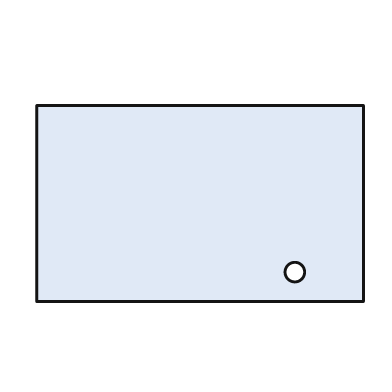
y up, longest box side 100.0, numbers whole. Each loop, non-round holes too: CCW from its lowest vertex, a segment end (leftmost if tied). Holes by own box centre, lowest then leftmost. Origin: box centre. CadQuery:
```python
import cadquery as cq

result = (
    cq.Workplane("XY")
    .moveTo(-50.0, -30.0)
    .lineTo(50.0, -30.0)
    .lineTo(50.0, 30.0)
    .lineTo(-50.0, 30.0)
    .close()
    .moveTo(29.0, -21.0)
    .circle(3.0)
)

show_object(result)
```